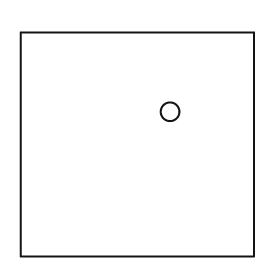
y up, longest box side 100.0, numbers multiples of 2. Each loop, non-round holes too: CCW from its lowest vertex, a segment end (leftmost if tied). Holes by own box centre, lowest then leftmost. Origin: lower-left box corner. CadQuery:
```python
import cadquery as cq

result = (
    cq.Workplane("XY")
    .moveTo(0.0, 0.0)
    .lineTo(100.0, 0.0)
    .lineTo(100.0, 96.0)
    .lineTo(0.0, 96.0)
    .close()
    .moveTo(64.0, 62.0)
    .circle(4.0)
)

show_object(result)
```